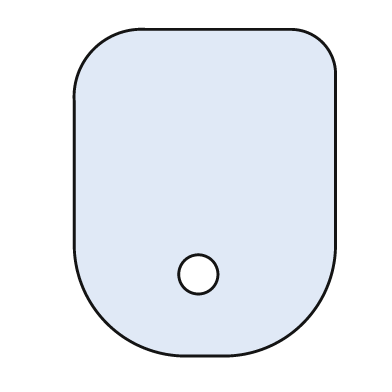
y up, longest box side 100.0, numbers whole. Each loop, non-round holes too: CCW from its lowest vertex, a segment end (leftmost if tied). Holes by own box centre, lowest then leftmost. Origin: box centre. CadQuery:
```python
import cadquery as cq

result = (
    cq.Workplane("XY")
    .moveTo(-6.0, -50.0)
    .lineTo(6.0, -50.0)
    .threePointArc((30.0, -40.0), (40.0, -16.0))
    .lineTo(40.0, 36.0)
    .threePointArc((36.0, 46.0), (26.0, 50.0))
    .lineTo(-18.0, 50.0)
    .threePointArc((-34.0, 44.0), (-40.0, 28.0))
    .lineTo(-40.0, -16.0)
    .threePointArc((-30.0, -40.0), (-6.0, -50.0))
    .close()
    .moveTo(-2.0, -25.0)
    .circle(6.0)
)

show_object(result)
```